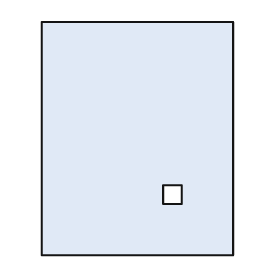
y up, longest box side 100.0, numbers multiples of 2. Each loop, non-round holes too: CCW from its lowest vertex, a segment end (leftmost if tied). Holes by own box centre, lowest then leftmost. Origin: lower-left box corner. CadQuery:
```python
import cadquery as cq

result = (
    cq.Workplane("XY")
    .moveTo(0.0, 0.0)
    .lineTo(82.0, 0.0)
    .lineTo(82.0, 100.0)
    .lineTo(0.0, 100.0)
    .close()
    .moveTo(52.0, 22.0)
    .lineTo(60.0, 22.0)
    .lineTo(60.0, 30.0)
    .lineTo(52.0, 30.0)
    .close()
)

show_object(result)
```